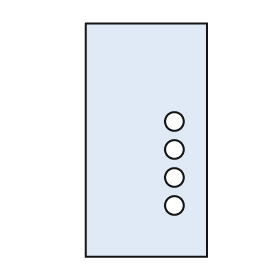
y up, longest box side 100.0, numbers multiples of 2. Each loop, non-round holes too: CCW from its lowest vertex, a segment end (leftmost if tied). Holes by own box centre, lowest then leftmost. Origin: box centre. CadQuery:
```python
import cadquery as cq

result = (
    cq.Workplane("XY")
    .moveTo(-26.0, -50.0)
    .lineTo(26.0, -50.0)
    .lineTo(26.0, 50.0)
    .lineTo(-26.0, 50.0)
    .close()
    .moveTo(12.0, -28.0)
    .circle(4.0)
    .moveTo(12.0, -16.0)
    .circle(4.0)
    .moveTo(12.0, -4.0)
    .circle(4.0)
    .moveTo(12.0, 8.0)
    .circle(4.0)
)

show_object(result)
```